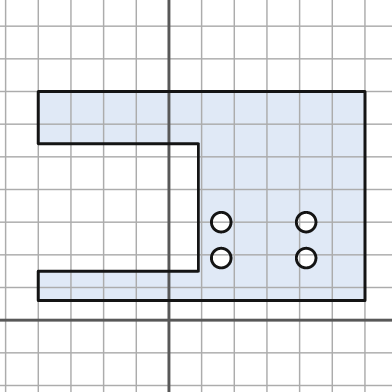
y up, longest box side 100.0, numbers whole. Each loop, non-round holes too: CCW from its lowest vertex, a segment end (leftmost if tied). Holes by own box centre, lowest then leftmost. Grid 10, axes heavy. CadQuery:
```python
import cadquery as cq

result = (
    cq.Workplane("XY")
    .moveTo(-40.0, 6.0)
    .lineTo(60.0, 6.0)
    .lineTo(60.0, 70.0)
    .lineTo(-40.0, 70.0)
    .lineTo(-40.0, 54.0)
    .lineTo(9.0, 54.0)
    .lineTo(9.0, 15.0)
    .lineTo(-40.0, 15.0)
    .close()
    .moveTo(16.0, 19.0)
    .circle(3.0)
    .moveTo(42.0, 19.0)
    .circle(3.0)
    .moveTo(16.0, 30.0)
    .circle(3.0)
    .moveTo(42.0, 30.0)
    .circle(3.0)
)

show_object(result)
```